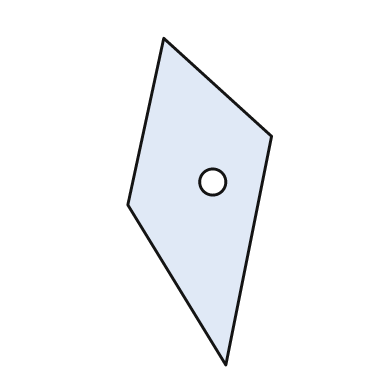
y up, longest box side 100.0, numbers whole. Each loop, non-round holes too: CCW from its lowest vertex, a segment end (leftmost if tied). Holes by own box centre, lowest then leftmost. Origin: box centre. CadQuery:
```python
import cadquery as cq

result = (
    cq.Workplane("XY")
    .moveTo(8.0, -50.0)
    .lineTo(22.0, 20.0)
    .lineTo(-11.0, 50.0)
    .lineTo(-22.0, -1.0)
    .close()
    .moveTo(4.0, 6.0)
    .circle(4.0)
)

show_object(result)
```